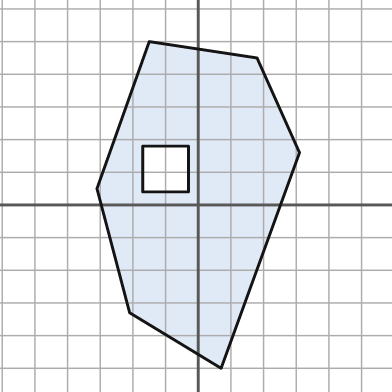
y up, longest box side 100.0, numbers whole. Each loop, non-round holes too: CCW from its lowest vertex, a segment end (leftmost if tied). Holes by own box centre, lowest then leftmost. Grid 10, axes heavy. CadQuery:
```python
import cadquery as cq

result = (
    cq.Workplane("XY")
    .moveTo(7.0, -50.0)
    .lineTo(31.0, 16.0)
    .lineTo(18.0, 45.0)
    .lineTo(-15.0, 50.0)
    .lineTo(-31.0, 5.0)
    .lineTo(-21.0, -33.0)
    .close()
    .moveTo(-17.0, 4.0)
    .lineTo(-3.0, 4.0)
    .lineTo(-3.0, 18.0)
    .lineTo(-17.0, 18.0)
    .close()
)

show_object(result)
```